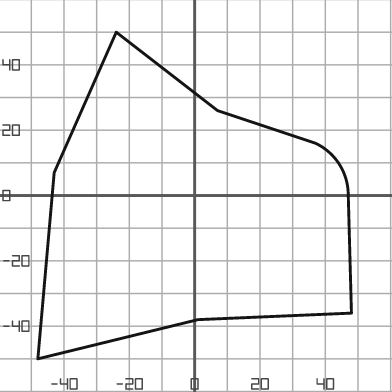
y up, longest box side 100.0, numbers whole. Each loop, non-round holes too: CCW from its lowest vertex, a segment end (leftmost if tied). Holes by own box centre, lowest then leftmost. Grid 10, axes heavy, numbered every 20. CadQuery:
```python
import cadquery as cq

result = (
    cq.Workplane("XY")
    .moveTo(-48.0, -50.0)
    .lineTo(1.0, -38.0)
    .lineTo(48.0, -36.0)
    .lineTo(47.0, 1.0)
    .threePointArc((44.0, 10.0), (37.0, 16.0))
    .lineTo(7.0, 26.0)
    .lineTo(-24.0, 50.0)
    .lineTo(-43.0, 7.0)
    .close()
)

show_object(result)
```